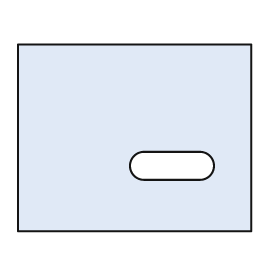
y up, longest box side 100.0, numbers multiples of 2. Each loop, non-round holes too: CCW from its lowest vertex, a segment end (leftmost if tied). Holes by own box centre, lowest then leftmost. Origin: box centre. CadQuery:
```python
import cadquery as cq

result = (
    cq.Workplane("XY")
    .moveTo(-50.0, -40.0)
    .lineTo(50.0, -40.0)
    .lineTo(50.0, 40.0)
    .lineTo(-50.0, 40.0)
    .close()
    .moveTo(4.0, -18.0)
    .lineTo(28.0, -18.0)
    .threePointArc((34.0, -12.0), (28.0, -6.0))
    .lineTo(4.0, -6.0)
    .threePointArc((-2.0, -12.0), (4.0, -18.0))
    .close()
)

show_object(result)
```